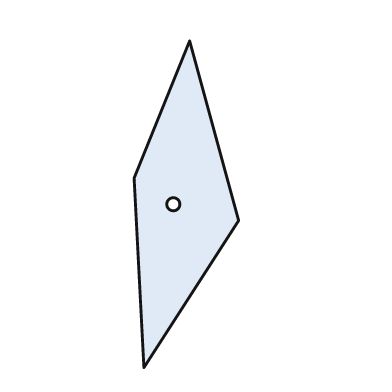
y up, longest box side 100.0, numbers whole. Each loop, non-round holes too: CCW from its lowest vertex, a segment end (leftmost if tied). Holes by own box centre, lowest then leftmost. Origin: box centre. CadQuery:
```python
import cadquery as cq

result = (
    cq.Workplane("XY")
    .moveTo(-13.0, -50.0)
    .lineTo(16.0, -5.0)
    .lineTo(1.0, 50.0)
    .lineTo(-16.0, 8.0)
    .close()
    .moveTo(-4.0, 0.0)
    .circle(2.0)
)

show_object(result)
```